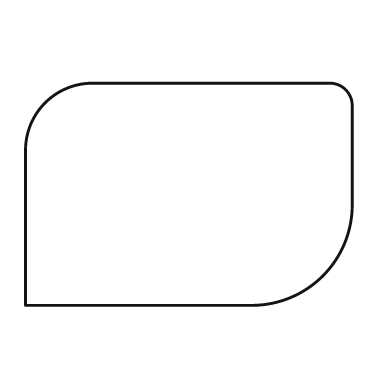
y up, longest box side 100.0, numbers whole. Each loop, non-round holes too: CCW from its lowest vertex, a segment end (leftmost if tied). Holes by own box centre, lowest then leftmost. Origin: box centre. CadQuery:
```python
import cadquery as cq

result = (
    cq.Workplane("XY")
    .moveTo(-50.0, -34.0)
    .lineTo(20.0, -34.0)
    .threePointArc((41.0, -25.0), (50.0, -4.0))
    .lineTo(50.0, 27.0)
    .threePointArc((48.0, 32.0), (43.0, 34.0))
    .lineTo(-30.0, 34.0)
    .threePointArc((-44.0, 28.0), (-50.0, 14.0))
    .close()
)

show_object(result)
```